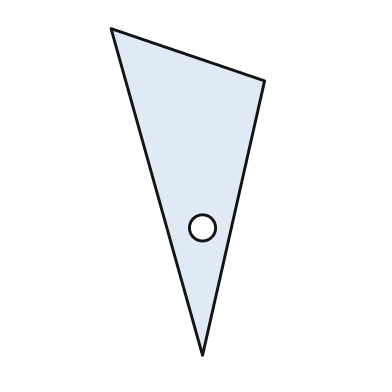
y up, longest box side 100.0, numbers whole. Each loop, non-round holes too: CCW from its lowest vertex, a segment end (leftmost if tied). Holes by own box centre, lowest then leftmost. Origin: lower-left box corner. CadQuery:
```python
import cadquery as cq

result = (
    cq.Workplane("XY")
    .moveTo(28.0, 0.0)
    .lineTo(47.0, 84.0)
    .lineTo(0.0, 100.0)
    .close()
    .moveTo(28.0, 39.0)
    .circle(4.0)
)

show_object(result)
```